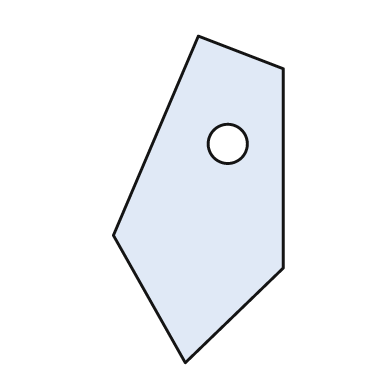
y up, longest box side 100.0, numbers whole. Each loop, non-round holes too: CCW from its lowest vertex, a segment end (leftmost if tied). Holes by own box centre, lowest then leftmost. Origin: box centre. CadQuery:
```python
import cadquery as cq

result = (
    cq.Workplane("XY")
    .moveTo(-4.0, -50.0)
    .lineTo(26.0, -21.0)
    .lineTo(26.0, 40.0)
    .lineTo(0.0, 50.0)
    .lineTo(-26.0, -11.0)
    .close()
    .moveTo(9.0, 17.0)
    .circle(6.0)
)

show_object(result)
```